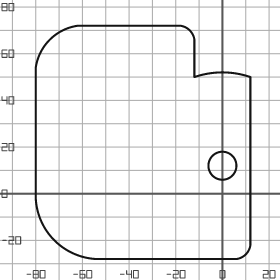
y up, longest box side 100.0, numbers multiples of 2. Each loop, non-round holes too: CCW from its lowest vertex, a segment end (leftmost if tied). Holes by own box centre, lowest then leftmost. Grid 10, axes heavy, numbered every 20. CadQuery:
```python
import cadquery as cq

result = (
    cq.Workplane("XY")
    .moveTo(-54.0, -28.0)
    .lineTo(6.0, -28.0)
    .threePointArc((10.0, -26.0), (12.0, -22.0))
    .lineTo(12.0, 50.0)
    .threePointArc((0.0, 52.0), (-12.0, 50.0))
    .lineTo(-12.0, 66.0)
    .threePointArc((-14.0, 70.0), (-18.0, 72.0))
    .lineTo(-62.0, 72.0)
    .threePointArc((-74.0, 66.0), (-80.0, 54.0))
    .lineTo(-80.0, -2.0)
    .threePointArc((-72.0, -20.0), (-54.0, -28.0))
    .close()
    .moveTo(0.0, 12.0)
    .circle(6.0)
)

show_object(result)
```